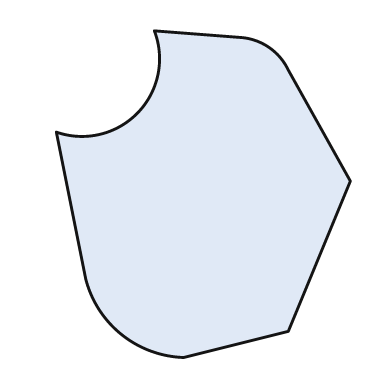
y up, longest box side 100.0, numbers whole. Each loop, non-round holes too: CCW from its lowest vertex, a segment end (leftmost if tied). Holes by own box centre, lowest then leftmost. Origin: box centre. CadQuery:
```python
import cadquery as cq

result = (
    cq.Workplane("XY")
    .moveTo(-6.0, -50.0)
    .lineTo(26.0, -42.0)
    .lineTo(45.0, 4.0)
    .lineTo(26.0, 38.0)
    .threePointArc((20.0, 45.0), (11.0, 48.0))
    .lineTo(-15.0, 50.0)
    .threePointArc((-20.0, 25.0), (-45.0, 19.0))
    .lineTo(-36.0, -26.0)
    .threePointArc((-25.0, -43.0), (-6.0, -50.0))
    .close()
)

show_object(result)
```